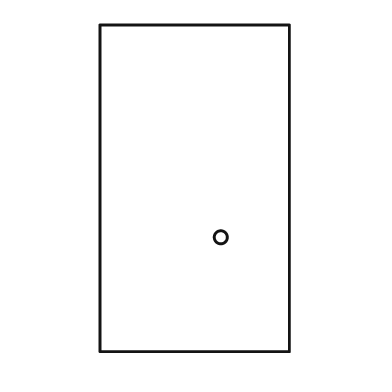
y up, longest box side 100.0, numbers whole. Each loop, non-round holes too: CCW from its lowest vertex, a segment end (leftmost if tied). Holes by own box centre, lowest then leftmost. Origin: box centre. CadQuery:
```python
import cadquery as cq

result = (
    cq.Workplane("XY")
    .moveTo(-29.0, -50.0)
    .lineTo(29.0, -50.0)
    .lineTo(29.0, 50.0)
    .lineTo(-29.0, 50.0)
    .close()
    .moveTo(8.0, -15.0)
    .circle(2.0)
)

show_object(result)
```